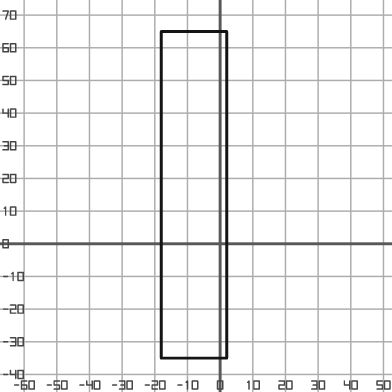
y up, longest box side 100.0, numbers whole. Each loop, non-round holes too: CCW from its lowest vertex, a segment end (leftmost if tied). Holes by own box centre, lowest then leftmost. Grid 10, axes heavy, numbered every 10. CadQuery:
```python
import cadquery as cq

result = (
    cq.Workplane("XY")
    .moveTo(-18.0, -35.0)
    .lineTo(2.0, -35.0)
    .lineTo(2.0, 65.0)
    .lineTo(-18.0, 65.0)
    .close()
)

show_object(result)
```